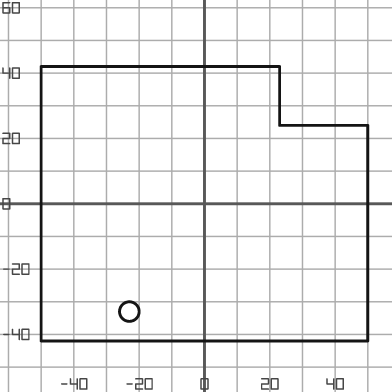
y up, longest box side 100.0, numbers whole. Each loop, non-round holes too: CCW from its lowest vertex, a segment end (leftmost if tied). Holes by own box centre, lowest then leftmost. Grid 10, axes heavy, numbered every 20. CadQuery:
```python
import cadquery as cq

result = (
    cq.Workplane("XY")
    .moveTo(-50.0, -42.0)
    .lineTo(50.0, -42.0)
    .lineTo(50.0, 24.0)
    .lineTo(23.0, 24.0)
    .lineTo(23.0, 42.0)
    .lineTo(-50.0, 42.0)
    .close()
    .moveTo(-23.0, -33.0)
    .circle(3.0)
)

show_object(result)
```